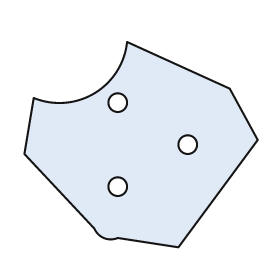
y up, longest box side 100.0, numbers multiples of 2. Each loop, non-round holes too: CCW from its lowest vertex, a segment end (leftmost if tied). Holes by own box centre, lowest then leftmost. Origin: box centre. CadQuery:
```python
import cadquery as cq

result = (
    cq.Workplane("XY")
    .moveTo(16.0, -44.0)
    .lineTo(50.0, 2.0)
    .lineTo(38.0, 24.0)
    .lineTo(-6.0, 44.0)
    .threePointArc((-20.0, 22.0), (-46.0, 20.0))
    .lineTo(-50.0, -4.0)
    .lineTo(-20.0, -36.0)
    .threePointArc((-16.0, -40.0), (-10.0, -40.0))
    .close()
    .moveTo(-10.0, -18.0)
    .circle(4.0)
    .moveTo(20.0, 0.0)
    .circle(4.0)
    .moveTo(-10.0, 18.0)
    .circle(4.0)
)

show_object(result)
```